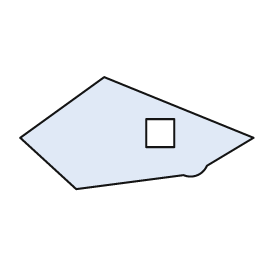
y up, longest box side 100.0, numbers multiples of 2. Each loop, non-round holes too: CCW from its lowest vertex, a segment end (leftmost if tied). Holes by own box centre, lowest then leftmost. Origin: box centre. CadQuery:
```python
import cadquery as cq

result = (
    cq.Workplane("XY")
    .moveTo(-26.0, -24.0)
    .lineTo(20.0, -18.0)
    .threePointArc((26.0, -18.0), (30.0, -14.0))
    .lineTo(50.0, -2.0)
    .lineTo(-14.0, 24.0)
    .lineTo(-50.0, -2.0)
    .close()
    .moveTo(4.0, -6.0)
    .lineTo(16.0, -6.0)
    .lineTo(16.0, 6.0)
    .lineTo(4.0, 6.0)
    .close()
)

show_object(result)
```